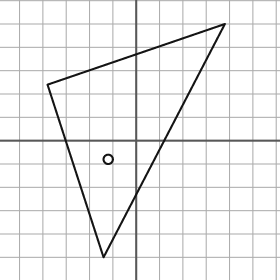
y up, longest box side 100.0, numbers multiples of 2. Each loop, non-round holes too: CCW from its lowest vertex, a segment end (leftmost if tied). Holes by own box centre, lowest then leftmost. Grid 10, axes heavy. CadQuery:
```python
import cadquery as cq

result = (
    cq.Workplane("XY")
    .moveTo(-14.0, -50.0)
    .lineTo(38.0, 50.0)
    .lineTo(-38.0, 24.0)
    .close()
    .moveTo(-12.0, -8.0)
    .circle(2.0)
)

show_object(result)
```